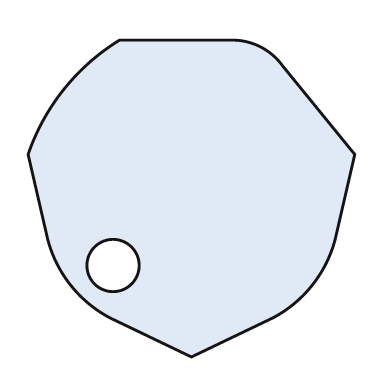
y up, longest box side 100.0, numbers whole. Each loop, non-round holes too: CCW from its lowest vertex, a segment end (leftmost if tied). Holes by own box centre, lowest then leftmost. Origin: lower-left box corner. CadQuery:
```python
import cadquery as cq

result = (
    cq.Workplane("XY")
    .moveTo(50.0, 0.0)
    .lineTo(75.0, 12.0)
    .threePointArc((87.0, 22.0), (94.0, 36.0))
    .lineTo(100.0, 62.0)
    .lineTo(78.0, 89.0)
    .threePointArc((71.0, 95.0), (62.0, 97.0))
    .lineTo(28.0, 97.0)
    .threePointArc((11.0, 82.0), (0.0, 62.0))
    .lineTo(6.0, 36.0)
    .threePointArc((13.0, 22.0), (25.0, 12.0))
    .close()
    .moveTo(26.0, 28.0)
    .circle(8.0)
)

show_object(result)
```